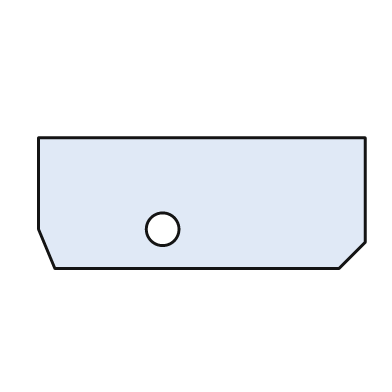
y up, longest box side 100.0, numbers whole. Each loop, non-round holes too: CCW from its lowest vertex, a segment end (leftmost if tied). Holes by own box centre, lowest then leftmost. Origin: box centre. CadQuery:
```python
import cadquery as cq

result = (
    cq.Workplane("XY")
    .moveTo(-45.0, -20.0)
    .lineTo(42.0, -20.0)
    .lineTo(50.0, -12.0)
    .lineTo(50.0, 20.0)
    .lineTo(-50.0, 20.0)
    .lineTo(-50.0, -8.0)
    .close()
    .moveTo(-12.0, -8.0)
    .circle(5.0)
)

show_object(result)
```